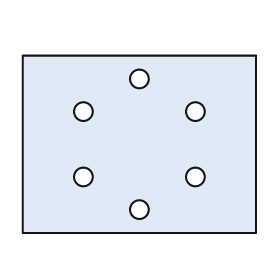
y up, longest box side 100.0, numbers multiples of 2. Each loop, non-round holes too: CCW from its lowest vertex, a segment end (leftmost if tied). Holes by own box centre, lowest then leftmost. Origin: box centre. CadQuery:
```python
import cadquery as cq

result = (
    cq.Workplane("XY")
    .moveTo(-50.0, -38.0)
    .lineTo(50.0, -38.0)
    .lineTo(50.0, 38.0)
    .lineTo(-50.0, 38.0)
    .close()
    .moveTo(0.0, -28.0)
    .circle(4.0)
    .moveTo(-24.0, -14.0)
    .circle(4.0)
    .moveTo(24.0, -14.0)
    .circle(4.0)
    .moveTo(-24.0, 14.0)
    .circle(4.0)
    .moveTo(24.0, 14.0)
    .circle(4.0)
    .moveTo(0.0, 28.0)
    .circle(4.0)
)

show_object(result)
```